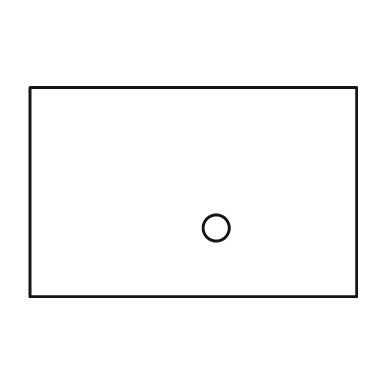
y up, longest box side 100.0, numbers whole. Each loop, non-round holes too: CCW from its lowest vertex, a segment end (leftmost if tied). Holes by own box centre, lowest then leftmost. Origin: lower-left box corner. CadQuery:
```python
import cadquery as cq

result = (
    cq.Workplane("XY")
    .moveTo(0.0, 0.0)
    .lineTo(100.0, 0.0)
    .lineTo(100.0, 64.0)
    .lineTo(0.0, 64.0)
    .close()
    .moveTo(57.0, 21.0)
    .circle(4.0)
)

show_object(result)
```